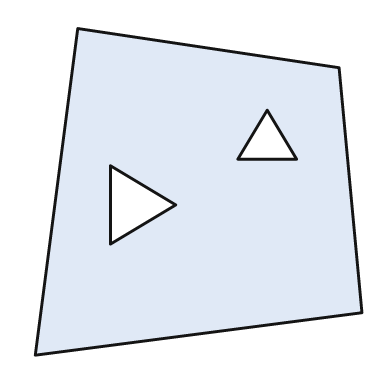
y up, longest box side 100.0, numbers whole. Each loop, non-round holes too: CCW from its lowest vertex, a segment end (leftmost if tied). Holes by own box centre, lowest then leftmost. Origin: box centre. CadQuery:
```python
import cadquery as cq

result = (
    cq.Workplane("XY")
    .moveTo(-50.0, -50.0)
    .lineTo(50.0, -37.0)
    .lineTo(43.0, 38.0)
    .lineTo(-37.0, 50.0)
    .close()
    .moveTo(-27.0, -16.0)
    .lineTo(-7.0, -4.0)
    .lineTo(-27.0, 8.0)
    .close()
    .moveTo(12.0, 10.0)
    .lineTo(30.0, 10.0)
    .lineTo(21.0, 25.0)
    .close()
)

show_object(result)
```